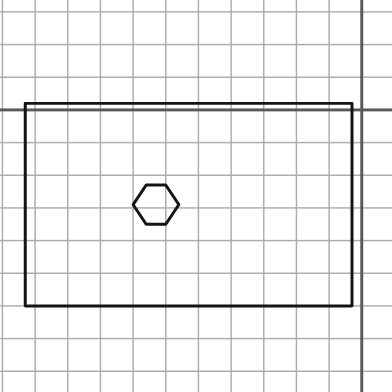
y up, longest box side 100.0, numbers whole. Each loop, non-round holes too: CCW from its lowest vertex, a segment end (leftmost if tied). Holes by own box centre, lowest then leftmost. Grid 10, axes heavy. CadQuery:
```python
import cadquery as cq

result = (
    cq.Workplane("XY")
    .moveTo(-103.0, -60.0)
    .lineTo(-3.0, -60.0)
    .lineTo(-3.0, 2.0)
    .lineTo(-103.0, 2.0)
    .close()
    .moveTo(-66.0, -35.0)
    .lineTo(-60.0, -35.0)
    .lineTo(-56.0, -29.0)
    .lineTo(-60.0, -23.0)
    .lineTo(-66.0, -23.0)
    .lineTo(-70.0, -29.0)
    .close()
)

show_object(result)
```